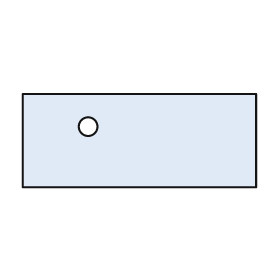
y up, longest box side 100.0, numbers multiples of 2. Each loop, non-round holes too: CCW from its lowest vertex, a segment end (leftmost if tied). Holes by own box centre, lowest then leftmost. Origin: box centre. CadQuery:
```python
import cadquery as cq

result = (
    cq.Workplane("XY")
    .moveTo(-50.0, -20.0)
    .lineTo(50.0, -20.0)
    .lineTo(50.0, 20.0)
    .lineTo(-50.0, 20.0)
    .close()
    .moveTo(-22.0, 6.0)
    .circle(4.0)
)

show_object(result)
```